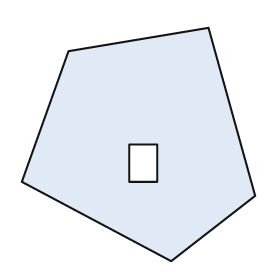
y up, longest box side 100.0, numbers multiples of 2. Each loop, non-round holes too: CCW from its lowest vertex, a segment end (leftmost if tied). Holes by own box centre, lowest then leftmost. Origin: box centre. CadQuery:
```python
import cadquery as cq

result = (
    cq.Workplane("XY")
    .moveTo(14.0, -50.0)
    .lineTo(50.0, -22.0)
    .lineTo(30.0, 50.0)
    .lineTo(-30.0, 40.0)
    .lineTo(-50.0, -16.0)
    .close()
    .moveTo(-4.0, -16.0)
    .lineTo(8.0, -16.0)
    .lineTo(8.0, 0.0)
    .lineTo(-4.0, 0.0)
    .close()
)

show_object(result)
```